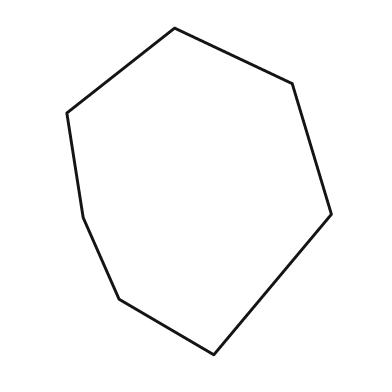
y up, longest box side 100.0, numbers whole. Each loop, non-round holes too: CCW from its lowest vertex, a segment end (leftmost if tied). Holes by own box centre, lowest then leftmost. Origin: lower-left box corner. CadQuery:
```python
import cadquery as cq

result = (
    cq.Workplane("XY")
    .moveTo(45.0, 0.0)
    .lineTo(81.0, 43.0)
    .lineTo(69.0, 83.0)
    .lineTo(33.0, 100.0)
    .lineTo(0.0, 74.0)
    .lineTo(5.0, 42.0)
    .lineTo(16.0, 17.0)
    .close()
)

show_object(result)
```